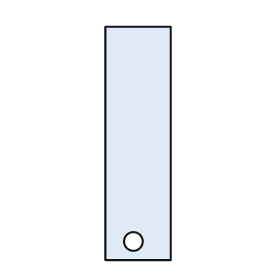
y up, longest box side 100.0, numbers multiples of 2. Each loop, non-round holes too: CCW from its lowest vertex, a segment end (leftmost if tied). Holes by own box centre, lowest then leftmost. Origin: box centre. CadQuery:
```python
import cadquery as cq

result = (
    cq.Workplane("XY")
    .moveTo(-14.0, -50.0)
    .lineTo(14.0, -50.0)
    .lineTo(14.0, 50.0)
    .lineTo(-14.0, 50.0)
    .close()
    .moveTo(-2.0, -42.0)
    .circle(4.0)
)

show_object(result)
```